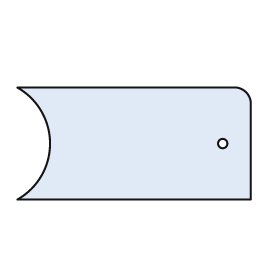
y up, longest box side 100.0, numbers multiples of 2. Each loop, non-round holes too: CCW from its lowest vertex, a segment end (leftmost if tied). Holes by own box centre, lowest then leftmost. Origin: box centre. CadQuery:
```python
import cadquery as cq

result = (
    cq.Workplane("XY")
    .moveTo(-50.0, -24.0)
    .lineTo(50.0, -24.0)
    .lineTo(50.0, 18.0)
    .threePointArc((48.0, 22.0), (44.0, 24.0))
    .lineTo(-50.0, 24.0)
    .threePointArc((-36.0, 0.0), (-50.0, -24.0))
    .close()
    .moveTo(38.0, 0.0)
    .circle(2.0)
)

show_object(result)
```